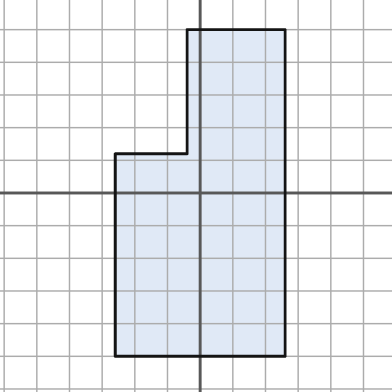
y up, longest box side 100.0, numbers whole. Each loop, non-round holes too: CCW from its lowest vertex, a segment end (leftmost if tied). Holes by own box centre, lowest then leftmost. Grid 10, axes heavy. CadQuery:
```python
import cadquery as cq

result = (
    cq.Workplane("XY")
    .moveTo(-26.0, -50.0)
    .lineTo(26.0, -50.0)
    .lineTo(26.0, 50.0)
    .lineTo(-4.0, 50.0)
    .lineTo(-4.0, 12.0)
    .lineTo(-26.0, 12.0)
    .close()
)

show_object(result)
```